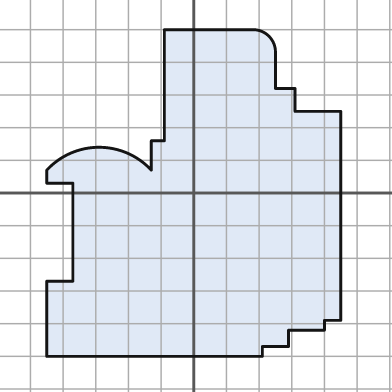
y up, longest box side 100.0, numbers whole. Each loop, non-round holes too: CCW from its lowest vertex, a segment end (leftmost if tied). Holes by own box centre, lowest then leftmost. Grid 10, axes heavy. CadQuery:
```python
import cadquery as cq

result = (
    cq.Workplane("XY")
    .moveTo(-45.0, -50.0)
    .lineTo(21.0, -50.0)
    .lineTo(21.0, -47.0)
    .lineTo(29.0, -47.0)
    .lineTo(29.0, -42.0)
    .lineTo(40.0, -42.0)
    .lineTo(40.0, -39.0)
    .lineTo(45.0, -39.0)
    .lineTo(45.0, 25.0)
    .lineTo(31.0, 25.0)
    .lineTo(31.0, 32.0)
    .lineTo(25.0, 32.0)
    .lineTo(25.0, 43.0)
    .threePointArc((23.0, 48.0), (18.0, 50.0))
    .lineTo(-9.0, 50.0)
    .lineTo(-9.0, 16.0)
    .lineTo(-13.0, 16.0)
    .lineTo(-13.0, 7.0)
    .threePointArc((-29.0, 14.0), (-45.0, 7.0))
    .lineTo(-45.0, 3.0)
    .lineTo(-37.0, 3.0)
    .lineTo(-37.0, -27.0)
    .lineTo(-45.0, -27.0)
    .close()
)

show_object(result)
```